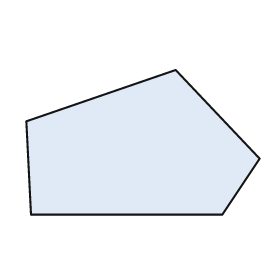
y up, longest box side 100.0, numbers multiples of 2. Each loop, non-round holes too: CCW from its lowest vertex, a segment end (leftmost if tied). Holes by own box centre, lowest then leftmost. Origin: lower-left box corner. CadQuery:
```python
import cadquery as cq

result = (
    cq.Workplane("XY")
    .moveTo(2.0, 0.0)
    .lineTo(84.0, 0.0)
    .lineTo(100.0, 24.0)
    .lineTo(64.0, 62.0)
    .lineTo(0.0, 40.0)
    .close()
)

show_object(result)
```